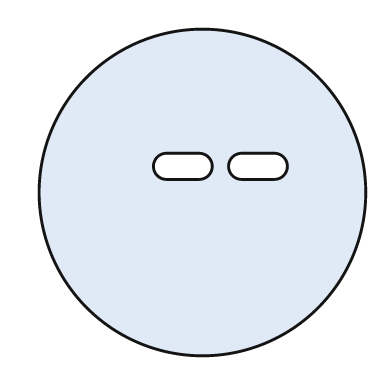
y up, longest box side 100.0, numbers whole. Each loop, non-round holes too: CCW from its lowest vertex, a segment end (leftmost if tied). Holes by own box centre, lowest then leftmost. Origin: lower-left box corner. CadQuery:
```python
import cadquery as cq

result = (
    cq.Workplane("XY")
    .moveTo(50.0, 50.0)
    .circle(50.0)
    .moveTo(39.0, 54.0)
    .lineTo(49.0, 54.0)
    .threePointArc((53.0, 58.0), (49.0, 62.0))
    .lineTo(39.0, 62.0)
    .threePointArc((35.0, 58.0), (39.0, 54.0))
    .close()
    .moveTo(62.0, 54.0)
    .lineTo(72.0, 54.0)
    .threePointArc((76.0, 58.0), (72.0, 62.0))
    .lineTo(62.0, 62.0)
    .threePointArc((58.0, 58.0), (62.0, 54.0))
    .close()
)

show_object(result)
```